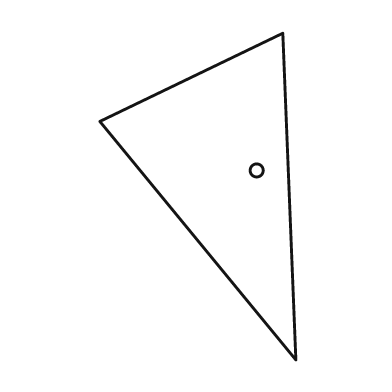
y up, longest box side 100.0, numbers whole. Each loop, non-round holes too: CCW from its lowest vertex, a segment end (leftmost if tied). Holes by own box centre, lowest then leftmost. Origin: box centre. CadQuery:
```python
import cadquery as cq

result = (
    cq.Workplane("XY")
    .moveTo(30.0, -50.0)
    .lineTo(26.0, 50.0)
    .lineTo(-30.0, 23.0)
    .close()
    .moveTo(18.0, 8.0)
    .circle(2.0)
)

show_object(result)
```